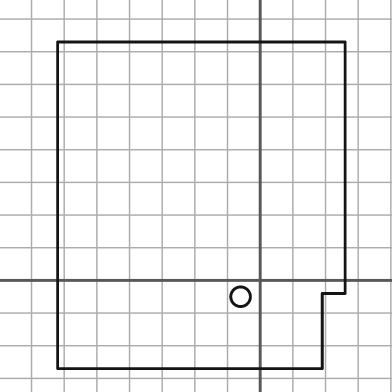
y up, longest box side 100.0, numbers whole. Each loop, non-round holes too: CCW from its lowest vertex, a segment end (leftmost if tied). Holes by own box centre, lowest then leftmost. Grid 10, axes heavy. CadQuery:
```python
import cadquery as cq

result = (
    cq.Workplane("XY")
    .moveTo(-62.0, -27.0)
    .lineTo(19.0, -27.0)
    .lineTo(19.0, -4.0)
    .lineTo(26.0, -4.0)
    .lineTo(26.0, 73.0)
    .lineTo(-62.0, 73.0)
    .close()
    .moveTo(-6.0, -5.0)
    .circle(3.0)
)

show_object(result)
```